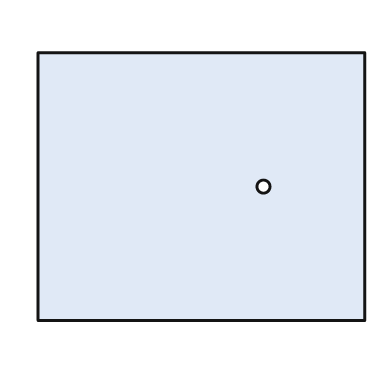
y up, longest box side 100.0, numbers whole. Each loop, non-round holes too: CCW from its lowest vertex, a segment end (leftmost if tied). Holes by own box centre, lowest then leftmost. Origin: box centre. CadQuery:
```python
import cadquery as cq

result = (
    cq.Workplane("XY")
    .moveTo(-50.0, -41.0)
    .lineTo(50.0, -41.0)
    .lineTo(50.0, 41.0)
    .lineTo(-50.0, 41.0)
    .close()
    .moveTo(19.0, 0.0)
    .circle(2.0)
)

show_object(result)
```